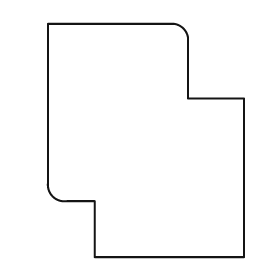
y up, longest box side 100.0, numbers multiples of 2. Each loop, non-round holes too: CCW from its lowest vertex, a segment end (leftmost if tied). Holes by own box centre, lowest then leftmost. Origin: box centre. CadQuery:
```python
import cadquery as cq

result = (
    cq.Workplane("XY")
    .moveTo(-22.0, -50.0)
    .lineTo(42.0, -50.0)
    .lineTo(42.0, 18.0)
    .lineTo(18.0, 18.0)
    .lineTo(18.0, 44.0)
    .threePointArc((16.0, 48.0), (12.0, 50.0))
    .lineTo(-42.0, 50.0)
    .lineTo(-42.0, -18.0)
    .threePointArc((-40.0, -24.0), (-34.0, -26.0))
    .lineTo(-22.0, -26.0)
    .close()
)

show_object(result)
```